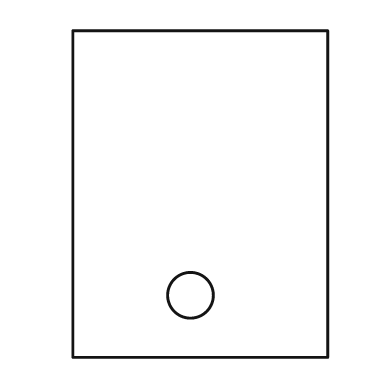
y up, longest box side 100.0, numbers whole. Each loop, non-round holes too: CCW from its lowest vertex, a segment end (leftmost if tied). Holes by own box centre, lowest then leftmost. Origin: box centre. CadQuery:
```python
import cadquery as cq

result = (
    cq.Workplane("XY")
    .moveTo(-39.0, -50.0)
    .lineTo(39.0, -50.0)
    .lineTo(39.0, 50.0)
    .lineTo(-39.0, 50.0)
    .close()
    .moveTo(-3.0, -31.0)
    .circle(7.0)
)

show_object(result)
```